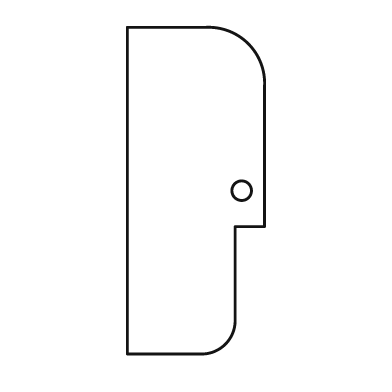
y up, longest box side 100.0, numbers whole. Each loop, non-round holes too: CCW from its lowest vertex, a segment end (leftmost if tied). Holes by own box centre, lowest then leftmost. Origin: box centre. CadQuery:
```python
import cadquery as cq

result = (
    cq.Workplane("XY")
    .moveTo(-21.0, -50.0)
    .lineTo(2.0, -50.0)
    .threePointArc((9.0, -47.0), (12.0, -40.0))
    .lineTo(12.0, -11.0)
    .lineTo(21.0, -11.0)
    .lineTo(21.0, 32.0)
    .threePointArc((16.0, 45.0), (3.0, 50.0))
    .lineTo(-21.0, 50.0)
    .close()
    .moveTo(14.0, 0.0)
    .circle(3.0)
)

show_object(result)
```